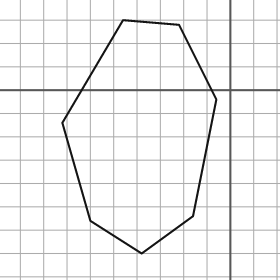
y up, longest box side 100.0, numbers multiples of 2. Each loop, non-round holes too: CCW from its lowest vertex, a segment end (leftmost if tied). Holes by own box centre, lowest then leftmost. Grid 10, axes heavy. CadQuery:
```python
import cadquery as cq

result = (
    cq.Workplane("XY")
    .moveTo(-38.0, -70.0)
    .lineTo(-16.0, -54.0)
    .lineTo(-6.0, -4.0)
    .lineTo(-22.0, 28.0)
    .lineTo(-46.0, 30.0)
    .lineTo(-72.0, -14.0)
    .lineTo(-60.0, -56.0)
    .close()
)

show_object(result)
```